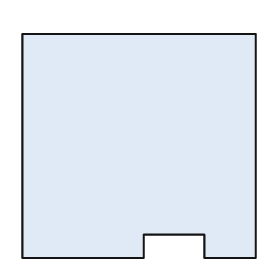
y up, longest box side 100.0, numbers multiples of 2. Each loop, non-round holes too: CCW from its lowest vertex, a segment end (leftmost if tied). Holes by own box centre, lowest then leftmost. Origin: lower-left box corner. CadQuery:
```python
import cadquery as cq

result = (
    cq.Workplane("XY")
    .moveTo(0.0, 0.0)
    .lineTo(52.0, 0.0)
    .lineTo(52.0, 10.0)
    .lineTo(78.0, 10.0)
    .lineTo(78.0, 0.0)
    .lineTo(100.0, 0.0)
    .lineTo(100.0, 96.0)
    .lineTo(0.0, 96.0)
    .close()
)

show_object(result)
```